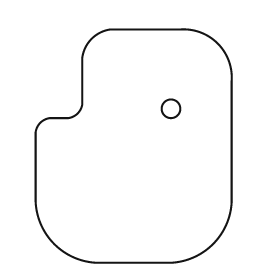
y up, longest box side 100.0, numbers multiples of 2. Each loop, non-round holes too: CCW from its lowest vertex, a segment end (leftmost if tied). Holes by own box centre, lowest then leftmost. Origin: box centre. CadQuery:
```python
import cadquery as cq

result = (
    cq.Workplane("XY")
    .moveTo(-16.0, -50.0)
    .lineTo(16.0, -50.0)
    .threePointArc((34.0, -42.0), (42.0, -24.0))
    .lineTo(42.0, 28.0)
    .threePointArc((36.0, 44.0), (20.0, 50.0))
    .lineTo(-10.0, 50.0)
    .threePointArc((-18.0, 46.0), (-22.0, 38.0))
    .lineTo(-22.0, 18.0)
    .threePointArc((-24.0, 14.0), (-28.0, 12.0))
    .lineTo(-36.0, 12.0)
    .threePointArc((-40.0, 10.0), (-42.0, 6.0))
    .lineTo(-42.0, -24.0)
    .threePointArc((-34.0, -42.0), (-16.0, -50.0))
    .close()
    .moveTo(16.0, 16.0)
    .circle(4.0)
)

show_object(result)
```